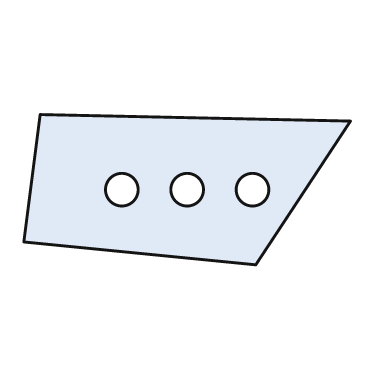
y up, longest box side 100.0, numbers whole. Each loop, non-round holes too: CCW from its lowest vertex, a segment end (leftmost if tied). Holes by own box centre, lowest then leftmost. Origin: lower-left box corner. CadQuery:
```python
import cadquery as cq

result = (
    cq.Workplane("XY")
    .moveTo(71.0, 0.0)
    .lineTo(100.0, 44.0)
    .lineTo(5.0, 46.0)
    .lineTo(0.0, 7.0)
    .close()
    .moveTo(30.0, 23.0)
    .circle(5.0)
    .moveTo(50.0, 23.0)
    .circle(5.0)
    .moveTo(70.0, 23.0)
    .circle(5.0)
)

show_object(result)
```